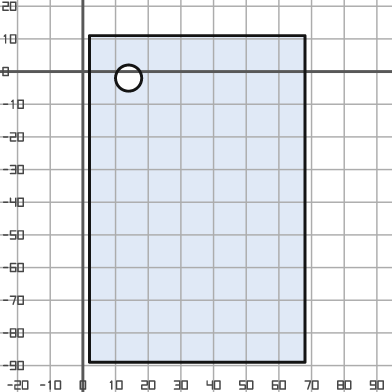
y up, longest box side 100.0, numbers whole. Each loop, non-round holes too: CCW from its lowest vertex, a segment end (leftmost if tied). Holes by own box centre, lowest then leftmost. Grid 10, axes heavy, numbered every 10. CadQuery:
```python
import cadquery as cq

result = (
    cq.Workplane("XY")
    .moveTo(2.0, -89.0)
    .lineTo(68.0, -89.0)
    .lineTo(68.0, 11.0)
    .lineTo(2.0, 11.0)
    .close()
    .moveTo(14.0, -2.0)
    .circle(4.0)
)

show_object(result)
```